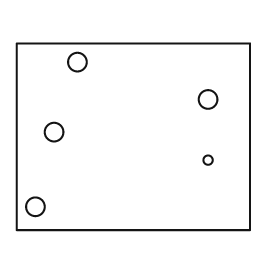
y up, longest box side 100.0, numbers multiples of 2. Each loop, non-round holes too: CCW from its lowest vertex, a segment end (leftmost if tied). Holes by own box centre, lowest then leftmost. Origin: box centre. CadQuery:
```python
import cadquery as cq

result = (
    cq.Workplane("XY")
    .moveTo(-50.0, -40.0)
    .lineTo(50.0, -40.0)
    .lineTo(50.0, 40.0)
    .lineTo(-50.0, 40.0)
    .close()
    .moveTo(-42.0, -30.0)
    .circle(4.0)
    .moveTo(32.0, -10.0)
    .circle(2.0)
    .moveTo(-34.0, 2.0)
    .circle(4.0)
    .moveTo(32.0, 16.0)
    .circle(4.0)
    .moveTo(-24.0, 32.0)
    .circle(4.0)
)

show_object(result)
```